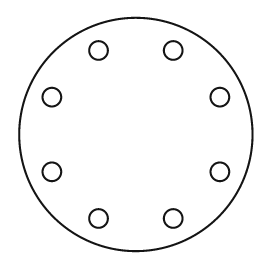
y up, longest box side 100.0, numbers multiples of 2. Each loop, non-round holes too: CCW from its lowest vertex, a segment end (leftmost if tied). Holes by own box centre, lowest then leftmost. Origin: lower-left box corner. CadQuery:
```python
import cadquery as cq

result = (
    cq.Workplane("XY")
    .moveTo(50.0, 50.0)
    .circle(50.0)
    .moveTo(34.0, 14.0)
    .circle(4.0)
    .moveTo(66.0, 14.0)
    .circle(4.0)
    .moveTo(14.0, 34.0)
    .circle(4.0)
    .moveTo(86.0, 34.0)
    .circle(4.0)
    .moveTo(14.0, 66.0)
    .circle(4.0)
    .moveTo(86.0, 66.0)
    .circle(4.0)
    .moveTo(34.0, 86.0)
    .circle(4.0)
    .moveTo(66.0, 86.0)
    .circle(4.0)
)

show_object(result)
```